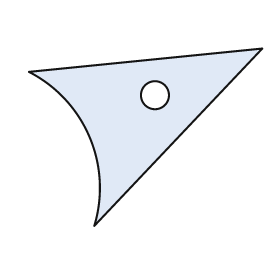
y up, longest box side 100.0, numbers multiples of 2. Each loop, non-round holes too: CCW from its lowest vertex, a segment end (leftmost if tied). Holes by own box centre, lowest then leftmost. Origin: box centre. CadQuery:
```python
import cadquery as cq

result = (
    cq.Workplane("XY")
    .moveTo(-22.0, -38.0)
    .lineTo(50.0, 38.0)
    .lineTo(-50.0, 28.0)
    .threePointArc((-24.0, 0.0), (-22.0, -38.0))
    .close()
    .moveTo(4.0, 18.0)
    .circle(6.0)
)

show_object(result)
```